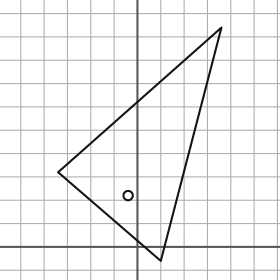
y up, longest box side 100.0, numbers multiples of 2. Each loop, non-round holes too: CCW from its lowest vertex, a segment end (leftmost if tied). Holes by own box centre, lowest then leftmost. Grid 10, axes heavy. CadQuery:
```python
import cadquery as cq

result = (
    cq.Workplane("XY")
    .moveTo(10.0, -6.0)
    .lineTo(36.0, 94.0)
    .lineTo(-34.0, 32.0)
    .close()
    .moveTo(-4.0, 22.0)
    .circle(2.0)
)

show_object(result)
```